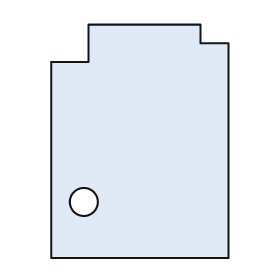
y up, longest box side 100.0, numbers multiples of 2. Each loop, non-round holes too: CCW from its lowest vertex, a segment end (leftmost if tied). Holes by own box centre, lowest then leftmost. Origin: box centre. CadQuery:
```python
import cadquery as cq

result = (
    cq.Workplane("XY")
    .moveTo(-38.0, -50.0)
    .lineTo(38.0, -50.0)
    .lineTo(38.0, 42.0)
    .lineTo(26.0, 42.0)
    .lineTo(26.0, 50.0)
    .lineTo(-22.0, 50.0)
    .lineTo(-22.0, 34.0)
    .lineTo(-38.0, 34.0)
    .close()
    .moveTo(-24.0, -26.0)
    .circle(6.0)
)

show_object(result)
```